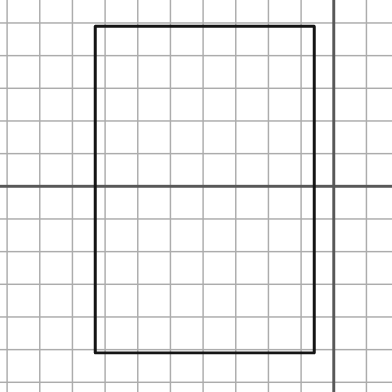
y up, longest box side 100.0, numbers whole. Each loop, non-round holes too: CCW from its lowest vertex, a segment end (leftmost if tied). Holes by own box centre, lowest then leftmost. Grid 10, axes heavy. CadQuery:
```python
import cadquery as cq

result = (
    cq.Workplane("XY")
    .moveTo(-73.0, -51.0)
    .lineTo(-6.0, -51.0)
    .lineTo(-6.0, 49.0)
    .lineTo(-73.0, 49.0)
    .close()
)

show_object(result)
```